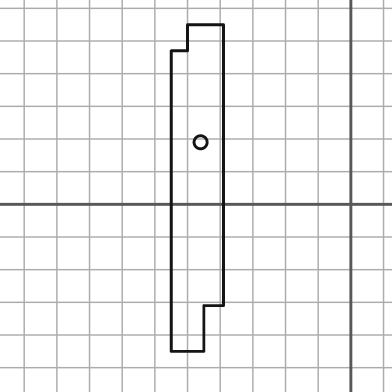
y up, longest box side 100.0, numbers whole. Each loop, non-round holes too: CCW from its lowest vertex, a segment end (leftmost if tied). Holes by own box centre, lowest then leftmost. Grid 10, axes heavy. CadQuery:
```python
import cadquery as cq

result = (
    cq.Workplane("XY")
    .moveTo(-55.0, -45.0)
    .lineTo(-45.0, -45.0)
    .lineTo(-45.0, -31.0)
    .lineTo(-39.0, -31.0)
    .lineTo(-39.0, 55.0)
    .lineTo(-50.0, 55.0)
    .lineTo(-50.0, 47.0)
    .lineTo(-55.0, 47.0)
    .close()
    .moveTo(-46.0, 19.0)
    .circle(2.0)
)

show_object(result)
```